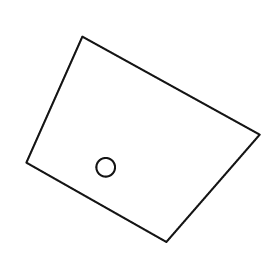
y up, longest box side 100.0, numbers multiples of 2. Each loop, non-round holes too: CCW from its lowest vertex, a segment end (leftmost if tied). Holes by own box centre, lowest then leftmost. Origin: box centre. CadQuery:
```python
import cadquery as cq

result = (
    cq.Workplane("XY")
    .moveTo(10.0, -44.0)
    .lineTo(50.0, 2.0)
    .lineTo(-26.0, 44.0)
    .lineTo(-50.0, -10.0)
    .close()
    .moveTo(-16.0, -12.0)
    .circle(4.0)
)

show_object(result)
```